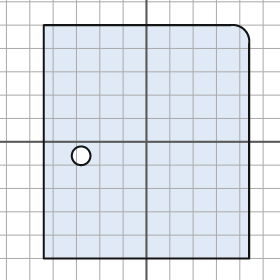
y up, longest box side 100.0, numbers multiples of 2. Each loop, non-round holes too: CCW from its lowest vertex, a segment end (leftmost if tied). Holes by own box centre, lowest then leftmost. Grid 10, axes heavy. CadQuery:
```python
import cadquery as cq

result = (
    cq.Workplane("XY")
    .moveTo(-44.0, -50.0)
    .lineTo(44.0, -50.0)
    .lineTo(44.0, 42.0)
    .threePointArc((42.0, 48.0), (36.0, 50.0))
    .lineTo(-44.0, 50.0)
    .close()
    .moveTo(-28.0, -6.0)
    .circle(4.0)
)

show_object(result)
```